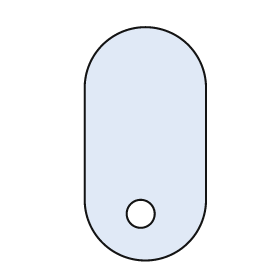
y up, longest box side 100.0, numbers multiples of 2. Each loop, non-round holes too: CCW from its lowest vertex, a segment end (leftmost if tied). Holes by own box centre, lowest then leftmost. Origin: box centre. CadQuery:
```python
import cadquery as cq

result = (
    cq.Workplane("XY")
    .moveTo(-26.0, -24.0)
    .threePointArc((0.0, -50.0), (26.0, -24.0))
    .lineTo(26.0, 24.0)
    .threePointArc((0.0, 50.0), (-26.0, 24.0))
    .close()
    .moveTo(-2.0, -30.0)
    .circle(6.0)
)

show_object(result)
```